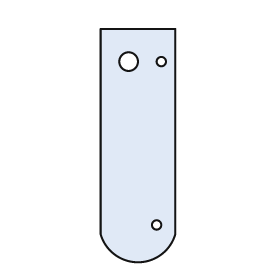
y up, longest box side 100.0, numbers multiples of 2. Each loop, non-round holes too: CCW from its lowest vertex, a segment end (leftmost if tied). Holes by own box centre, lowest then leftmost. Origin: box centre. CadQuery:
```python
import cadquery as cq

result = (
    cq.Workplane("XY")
    .moveTo(-16.0, -38.0)
    .threePointArc((0.0, -50.0), (16.0, -38.0))
    .lineTo(16.0, 50.0)
    .lineTo(-16.0, 50.0)
    .close()
    .moveTo(8.0, -34.0)
    .circle(2.0)
    .moveTo(-4.0, 36.0)
    .circle(4.0)
    .moveTo(10.0, 36.0)
    .circle(2.0)
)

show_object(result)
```